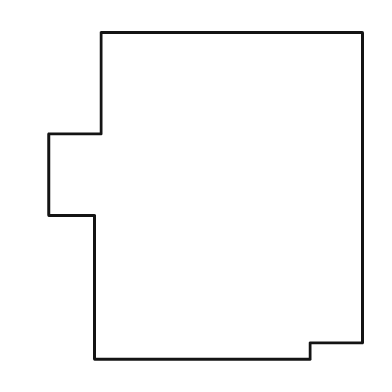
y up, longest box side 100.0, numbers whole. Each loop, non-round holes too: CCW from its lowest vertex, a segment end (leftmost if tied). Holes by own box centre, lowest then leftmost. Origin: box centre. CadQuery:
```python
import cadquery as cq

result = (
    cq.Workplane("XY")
    .moveTo(-34.0, -50.0)
    .lineTo(32.0, -50.0)
    .lineTo(32.0, -45.0)
    .lineTo(48.0, -45.0)
    .lineTo(48.0, 50.0)
    .lineTo(-32.0, 50.0)
    .lineTo(-32.0, 19.0)
    .lineTo(-48.0, 19.0)
    .lineTo(-48.0, -6.0)
    .lineTo(-34.0, -6.0)
    .close()
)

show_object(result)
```